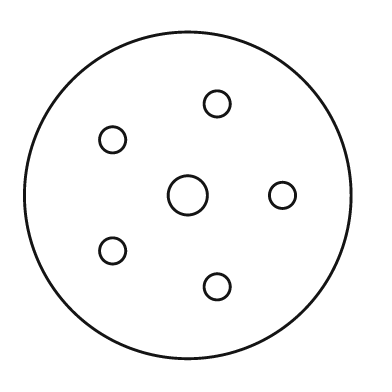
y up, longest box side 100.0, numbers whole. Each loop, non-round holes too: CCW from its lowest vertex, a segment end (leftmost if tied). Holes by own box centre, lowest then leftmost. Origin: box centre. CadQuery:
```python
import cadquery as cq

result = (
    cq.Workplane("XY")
    .moveTo(0.0, 0.0)
    .circle(50.0)
    .moveTo(9.0, -28.0)
    .circle(4.0)
    .moveTo(-23.0, -17.0)
    .circle(4.0)
    .moveTo(0.0, 0.0)
    .circle(6.0)
    .moveTo(29.0, 0.0)
    .circle(4.0)
    .moveTo(-23.0, 17.0)
    .circle(4.0)
    .moveTo(9.0, 28.0)
    .circle(4.0)
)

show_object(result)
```